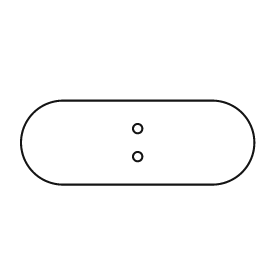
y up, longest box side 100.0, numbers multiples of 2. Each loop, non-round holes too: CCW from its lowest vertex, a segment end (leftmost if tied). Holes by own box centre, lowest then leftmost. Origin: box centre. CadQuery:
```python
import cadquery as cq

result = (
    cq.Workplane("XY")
    .moveTo(-32.0, -18.0)
    .lineTo(32.0, -18.0)
    .threePointArc((50.0, 0.0), (32.0, 18.0))
    .lineTo(-32.0, 18.0)
    .threePointArc((-50.0, 0.0), (-32.0, -18.0))
    .close()
    .moveTo(0.0, -6.0)
    .circle(2.0)
    .moveTo(0.0, 6.0)
    .circle(2.0)
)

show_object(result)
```